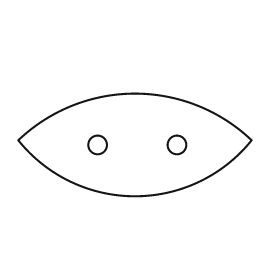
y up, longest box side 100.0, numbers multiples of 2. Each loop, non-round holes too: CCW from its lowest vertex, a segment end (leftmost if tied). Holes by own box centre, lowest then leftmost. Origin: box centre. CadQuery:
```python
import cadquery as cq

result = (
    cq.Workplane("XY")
    .moveTo(-50.0, 2.0)
    .threePointArc((0.0, -22.0), (50.0, 2.0))
    .threePointArc((0.0, 22.0), (-50.0, 2.0))
    .close()
    .moveTo(-16.0, 0.0)
    .circle(4.0)
    .moveTo(18.0, 0.0)
    .circle(4.0)
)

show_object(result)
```